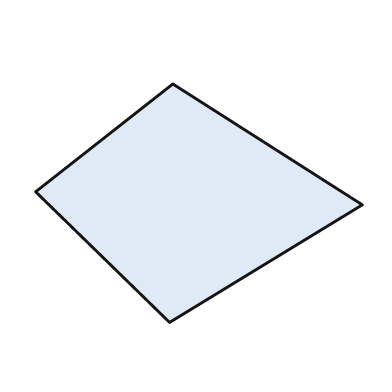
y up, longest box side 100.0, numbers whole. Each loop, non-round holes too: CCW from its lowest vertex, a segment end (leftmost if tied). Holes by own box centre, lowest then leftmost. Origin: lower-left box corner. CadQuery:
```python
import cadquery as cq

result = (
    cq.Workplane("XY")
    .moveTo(41.0, 0.0)
    .lineTo(100.0, 36.0)
    .lineTo(42.0, 73.0)
    .lineTo(0.0, 40.0)
    .close()
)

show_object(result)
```